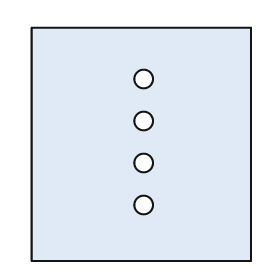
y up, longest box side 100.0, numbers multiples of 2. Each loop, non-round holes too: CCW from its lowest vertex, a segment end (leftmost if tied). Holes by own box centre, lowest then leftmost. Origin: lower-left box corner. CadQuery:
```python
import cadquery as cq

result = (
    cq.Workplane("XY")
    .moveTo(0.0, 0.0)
    .lineTo(94.0, 0.0)
    .lineTo(94.0, 100.0)
    .lineTo(0.0, 100.0)
    .close()
    .moveTo(48.0, 24.0)
    .circle(4.0)
    .moveTo(48.0, 42.0)
    .circle(4.0)
    .moveTo(48.0, 60.0)
    .circle(4.0)
    .moveTo(48.0, 78.0)
    .circle(4.0)
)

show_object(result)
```